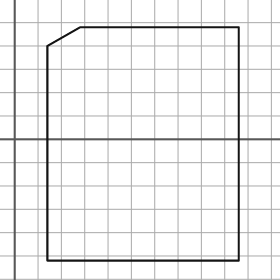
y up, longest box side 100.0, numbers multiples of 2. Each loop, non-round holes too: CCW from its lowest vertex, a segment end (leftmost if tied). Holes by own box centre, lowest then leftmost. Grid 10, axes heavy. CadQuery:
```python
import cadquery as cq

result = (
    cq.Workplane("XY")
    .moveTo(14.0, -52.0)
    .lineTo(96.0, -52.0)
    .lineTo(96.0, 48.0)
    .lineTo(28.0, 48.0)
    .lineTo(14.0, 40.0)
    .close()
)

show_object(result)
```